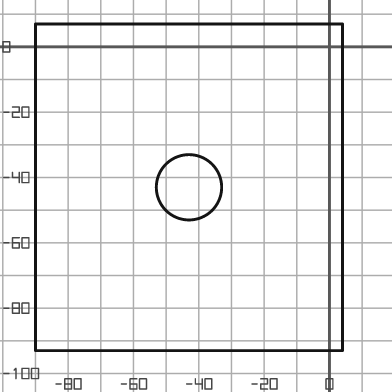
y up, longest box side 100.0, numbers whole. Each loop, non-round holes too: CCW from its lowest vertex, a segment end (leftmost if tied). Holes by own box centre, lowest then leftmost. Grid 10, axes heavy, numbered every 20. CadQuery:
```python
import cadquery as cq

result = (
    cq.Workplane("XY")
    .moveTo(-90.0, -93.0)
    .lineTo(4.0, -93.0)
    .lineTo(4.0, 7.0)
    .lineTo(-90.0, 7.0)
    .close()
    .moveTo(-43.0, -43.0)
    .circle(10.0)
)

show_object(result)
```